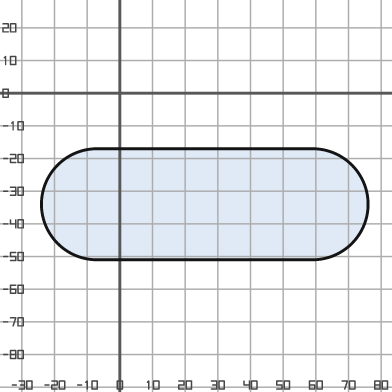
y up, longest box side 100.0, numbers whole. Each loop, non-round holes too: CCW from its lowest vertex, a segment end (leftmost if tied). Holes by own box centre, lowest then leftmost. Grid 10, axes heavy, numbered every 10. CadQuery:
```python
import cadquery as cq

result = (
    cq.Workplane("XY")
    .moveTo(-7.0, -51.0)
    .lineTo(59.0, -51.0)
    .threePointArc((76.0, -34.0), (59.0, -17.0))
    .lineTo(-7.0, -17.0)
    .threePointArc((-24.0, -34.0), (-7.0, -51.0))
    .close()
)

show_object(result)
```